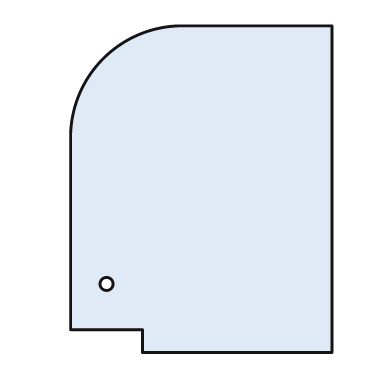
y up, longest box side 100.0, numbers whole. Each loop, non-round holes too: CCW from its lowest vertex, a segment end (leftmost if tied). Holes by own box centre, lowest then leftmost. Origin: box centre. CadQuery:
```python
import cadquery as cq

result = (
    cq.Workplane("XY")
    .moveTo(-18.0, -50.0)
    .lineTo(40.0, -50.0)
    .lineTo(40.0, 50.0)
    .lineTo(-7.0, 50.0)
    .threePointArc((-30.0, 40.0), (-40.0, 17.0))
    .lineTo(-40.0, -43.0)
    .lineTo(-18.0, -43.0)
    .close()
    .moveTo(-29.0, -29.0)
    .circle(2.0)
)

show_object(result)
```